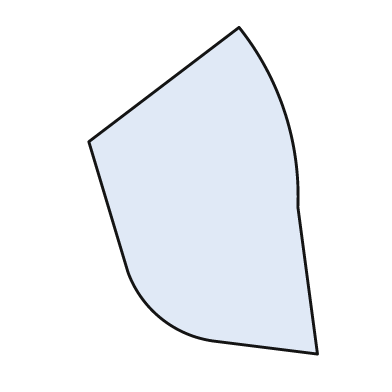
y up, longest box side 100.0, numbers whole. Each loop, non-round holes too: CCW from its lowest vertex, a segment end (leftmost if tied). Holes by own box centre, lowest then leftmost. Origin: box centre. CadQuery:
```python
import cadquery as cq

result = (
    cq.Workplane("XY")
    .moveTo(35.0, -50.0)
    .lineTo(29.0, -5.0)
    .threePointArc((25.0, 24.0), (11.0, 50.0))
    .lineTo(-35.0, 15.0)
    .lineTo(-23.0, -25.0)
    .threePointArc((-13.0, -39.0), (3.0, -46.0))
    .close()
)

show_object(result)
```